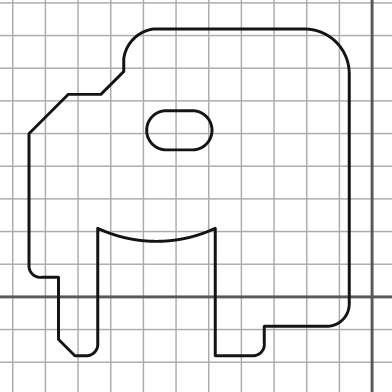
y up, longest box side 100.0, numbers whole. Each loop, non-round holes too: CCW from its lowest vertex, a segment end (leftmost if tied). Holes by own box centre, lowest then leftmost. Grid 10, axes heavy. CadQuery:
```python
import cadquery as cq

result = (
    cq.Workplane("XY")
    .moveTo(-91.0, -18.0)
    .lineTo(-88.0, -18.0)
    .threePointArc((-85.0, -17.0), (-84.0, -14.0))
    .lineTo(-84.0, 21.0)
    .threePointArc((-66.0, 17.0), (-48.0, 21.0))
    .lineTo(-48.0, -18.0)
    .lineTo(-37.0, -18.0)
    .threePointArc((-34.0, -17.0), (-33.0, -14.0))
    .lineTo(-33.0, -9.0)
    .lineTo(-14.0, -9.0)
    .threePointArc((-9.0, -7.0), (-7.0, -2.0))
    .lineTo(-7.0, 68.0)
    .threePointArc((-11.0, 78.0), (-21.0, 82.0))
    .lineTo(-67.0, 82.0)
    .threePointArc((-73.0, 79.0), (-76.0, 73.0))
    .lineTo(-76.0, 69.0)
    .lineTo(-83.0, 62.0)
    .lineTo(-93.0, 62.0)
    .lineTo(-105.0, 50.0)
    .lineTo(-105.0, 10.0)
    .threePointArc((-104.0, 7.0), (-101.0, 6.0))
    .lineTo(-96.0, 6.0)
    .lineTo(-96.0, -13.0)
    .close()
    .moveTo(-63.0, 45.0)
    .lineTo(-55.0, 45.0)
    .threePointArc((-49.0, 51.0), (-55.0, 57.0))
    .lineTo(-63.0, 57.0)
    .threePointArc((-69.0, 51.0), (-63.0, 45.0))
    .close()
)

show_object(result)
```